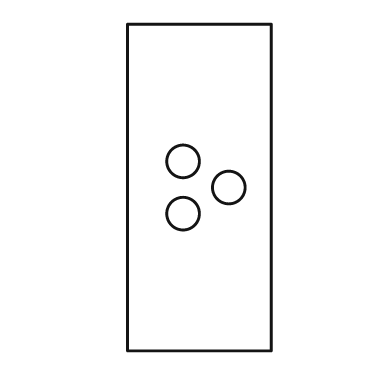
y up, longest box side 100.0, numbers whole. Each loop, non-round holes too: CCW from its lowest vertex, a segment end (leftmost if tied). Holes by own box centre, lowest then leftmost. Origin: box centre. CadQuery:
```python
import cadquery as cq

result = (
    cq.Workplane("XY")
    .moveTo(-22.0, -50.0)
    .lineTo(22.0, -50.0)
    .lineTo(22.0, 50.0)
    .lineTo(-22.0, 50.0)
    .close()
    .moveTo(-5.0, -8.0)
    .circle(5.0)
    .moveTo(9.0, 0.0)
    .circle(5.0)
    .moveTo(-5.0, 8.0)
    .circle(5.0)
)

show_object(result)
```